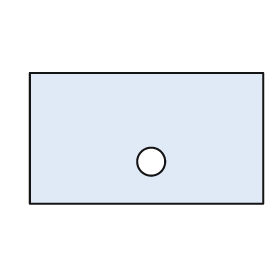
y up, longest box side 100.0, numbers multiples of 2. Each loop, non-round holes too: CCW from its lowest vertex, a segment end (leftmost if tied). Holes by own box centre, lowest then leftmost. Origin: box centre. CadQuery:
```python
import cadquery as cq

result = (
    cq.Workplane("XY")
    .moveTo(-50.0, -28.0)
    .lineTo(50.0, -28.0)
    .lineTo(50.0, 28.0)
    .lineTo(-50.0, 28.0)
    .close()
    .moveTo(2.0, -10.0)
    .circle(6.0)
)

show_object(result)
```